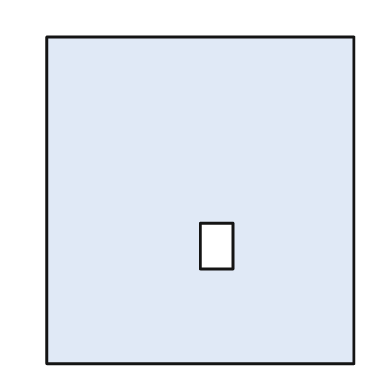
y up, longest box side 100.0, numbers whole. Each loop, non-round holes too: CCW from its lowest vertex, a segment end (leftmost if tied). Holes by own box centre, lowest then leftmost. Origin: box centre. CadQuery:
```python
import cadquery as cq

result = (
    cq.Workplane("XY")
    .moveTo(-47.0, -50.0)
    .lineTo(47.0, -50.0)
    .lineTo(47.0, 50.0)
    .lineTo(-47.0, 50.0)
    .close()
    .moveTo(0.0, -21.0)
    .lineTo(10.0, -21.0)
    .lineTo(10.0, -7.0)
    .lineTo(0.0, -7.0)
    .close()
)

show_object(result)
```